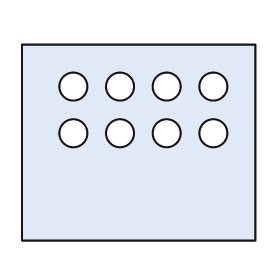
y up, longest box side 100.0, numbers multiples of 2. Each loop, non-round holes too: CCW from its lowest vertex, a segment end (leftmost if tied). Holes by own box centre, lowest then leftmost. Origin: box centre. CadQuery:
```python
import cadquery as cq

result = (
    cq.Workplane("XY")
    .moveTo(-50.0, -42.0)
    .lineTo(50.0, -42.0)
    .lineTo(50.0, 42.0)
    .lineTo(-50.0, 42.0)
    .close()
    .moveTo(-28.0, 4.0)
    .circle(6.0)
    .moveTo(-8.0, 4.0)
    .circle(6.0)
    .moveTo(12.0, 4.0)
    .circle(6.0)
    .moveTo(32.0, 4.0)
    .circle(6.0)
    .moveTo(-28.0, 24.0)
    .circle(6.0)
    .moveTo(-8.0, 24.0)
    .circle(6.0)
    .moveTo(12.0, 24.0)
    .circle(6.0)
    .moveTo(32.0, 24.0)
    .circle(6.0)
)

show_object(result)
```